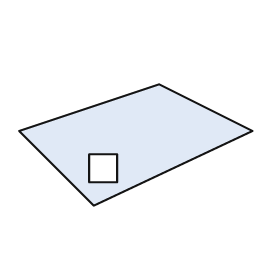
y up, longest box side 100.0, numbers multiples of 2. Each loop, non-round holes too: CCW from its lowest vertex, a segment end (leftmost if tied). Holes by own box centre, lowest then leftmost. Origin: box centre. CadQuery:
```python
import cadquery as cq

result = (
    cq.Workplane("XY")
    .moveTo(-18.0, -26.0)
    .lineTo(50.0, 6.0)
    .lineTo(10.0, 26.0)
    .lineTo(-50.0, 6.0)
    .close()
    .moveTo(-20.0, -16.0)
    .lineTo(-8.0, -16.0)
    .lineTo(-8.0, -4.0)
    .lineTo(-20.0, -4.0)
    .close()
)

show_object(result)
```